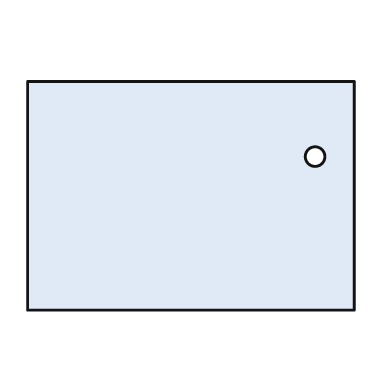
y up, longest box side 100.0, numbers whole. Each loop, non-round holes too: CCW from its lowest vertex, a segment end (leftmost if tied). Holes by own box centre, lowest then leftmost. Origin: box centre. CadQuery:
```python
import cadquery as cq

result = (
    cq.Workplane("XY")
    .moveTo(-50.0, -35.0)
    .lineTo(50.0, -35.0)
    .lineTo(50.0, 35.0)
    .lineTo(-50.0, 35.0)
    .close()
    .moveTo(38.0, 12.0)
    .circle(3.0)
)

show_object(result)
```